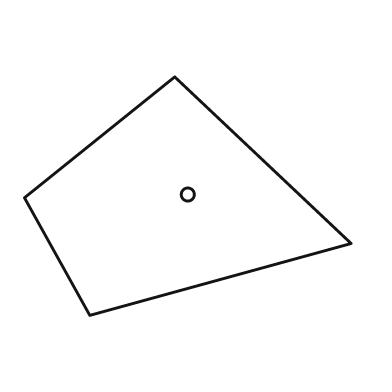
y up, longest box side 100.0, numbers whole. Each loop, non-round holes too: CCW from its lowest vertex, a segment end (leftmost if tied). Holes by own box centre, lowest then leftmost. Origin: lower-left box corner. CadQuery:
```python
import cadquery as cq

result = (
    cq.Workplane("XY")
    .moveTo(20.0, 0.0)
    .lineTo(100.0, 22.0)
    .lineTo(46.0, 73.0)
    .lineTo(0.0, 36.0)
    .close()
    .moveTo(50.0, 37.0)
    .circle(2.0)
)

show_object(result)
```